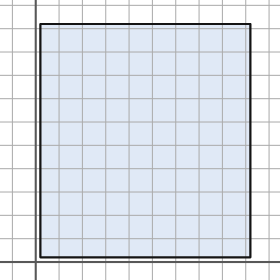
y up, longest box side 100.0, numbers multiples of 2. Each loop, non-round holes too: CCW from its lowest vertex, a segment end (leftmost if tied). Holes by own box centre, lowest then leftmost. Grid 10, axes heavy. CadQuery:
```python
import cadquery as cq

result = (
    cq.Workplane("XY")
    .moveTo(2.0, 2.0)
    .lineTo(92.0, 2.0)
    .lineTo(92.0, 102.0)
    .lineTo(2.0, 102.0)
    .close()
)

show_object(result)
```